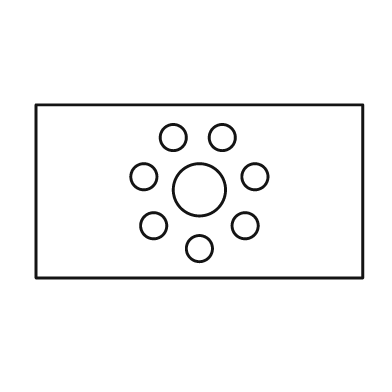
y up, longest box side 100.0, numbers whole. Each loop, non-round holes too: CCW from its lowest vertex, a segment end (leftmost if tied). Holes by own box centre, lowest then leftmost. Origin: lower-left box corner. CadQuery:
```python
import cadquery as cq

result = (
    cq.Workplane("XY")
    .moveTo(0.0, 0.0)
    .lineTo(100.0, 0.0)
    .lineTo(100.0, 53.0)
    .lineTo(0.0, 53.0)
    .close()
    .moveTo(50.0, 9.0)
    .circle(4.0)
    .moveTo(36.0, 16.0)
    .circle(4.0)
    .moveTo(64.0, 16.0)
    .circle(4.0)
    .moveTo(50.0, 27.0)
    .circle(8.0)
    .moveTo(33.0, 31.0)
    .circle(4.0)
    .moveTo(67.0, 31.0)
    .circle(4.0)
    .moveTo(42.0, 43.0)
    .circle(4.0)
    .moveTo(57.0, 43.0)
    .circle(4.0)
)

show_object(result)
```